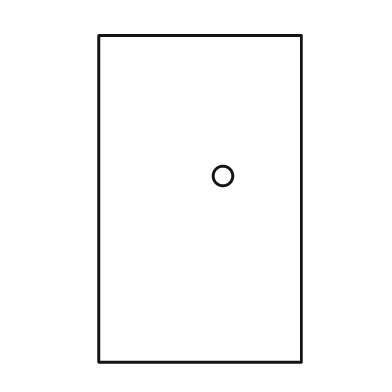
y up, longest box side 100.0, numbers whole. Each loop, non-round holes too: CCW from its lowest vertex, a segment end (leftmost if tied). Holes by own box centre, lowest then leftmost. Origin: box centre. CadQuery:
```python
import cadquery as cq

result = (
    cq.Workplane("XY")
    .moveTo(-31.0, -50.0)
    .lineTo(31.0, -50.0)
    .lineTo(31.0, 50.0)
    .lineTo(-31.0, 50.0)
    .close()
    .moveTo(7.0, 7.0)
    .circle(3.0)
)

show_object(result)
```